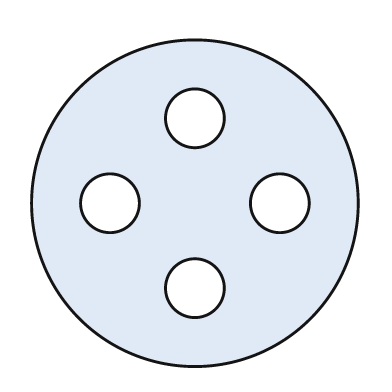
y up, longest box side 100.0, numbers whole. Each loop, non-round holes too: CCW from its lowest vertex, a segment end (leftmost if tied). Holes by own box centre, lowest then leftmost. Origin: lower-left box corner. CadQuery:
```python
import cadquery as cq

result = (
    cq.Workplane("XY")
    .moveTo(50.0, 50.0)
    .circle(50.0)
    .moveTo(50.0, 24.0)
    .circle(9.0)
    .moveTo(24.0, 50.0)
    .circle(9.0)
    .moveTo(76.0, 50.0)
    .circle(9.0)
    .moveTo(50.0, 76.0)
    .circle(9.0)
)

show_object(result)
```